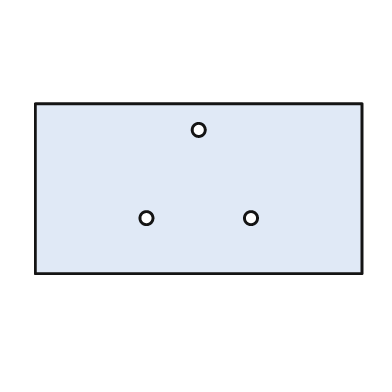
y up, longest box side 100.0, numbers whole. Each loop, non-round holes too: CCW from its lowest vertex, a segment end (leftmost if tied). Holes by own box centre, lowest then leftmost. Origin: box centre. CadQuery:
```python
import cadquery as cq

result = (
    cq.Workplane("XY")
    .moveTo(-50.0, -26.0)
    .lineTo(50.0, -26.0)
    .lineTo(50.0, 26.0)
    .lineTo(-50.0, 26.0)
    .close()
    .moveTo(-16.0, -9.0)
    .circle(2.0)
    .moveTo(16.0, -9.0)
    .circle(2.0)
    .moveTo(0.0, 18.0)
    .circle(2.0)
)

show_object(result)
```